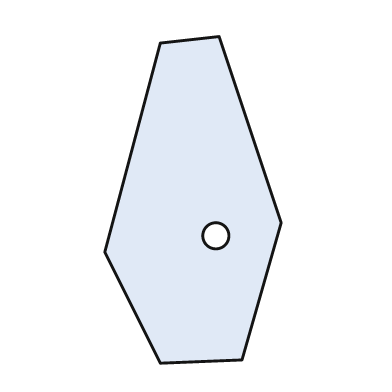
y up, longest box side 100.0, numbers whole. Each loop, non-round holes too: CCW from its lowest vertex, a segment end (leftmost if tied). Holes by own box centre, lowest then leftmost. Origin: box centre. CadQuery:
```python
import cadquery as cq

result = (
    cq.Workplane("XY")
    .moveTo(-10.0, -50.0)
    .lineTo(15.0, -49.0)
    .lineTo(27.0, -7.0)
    .lineTo(8.0, 50.0)
    .lineTo(-10.0, 48.0)
    .lineTo(-27.0, -16.0)
    .close()
    .moveTo(7.0, -11.0)
    .circle(4.0)
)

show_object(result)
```